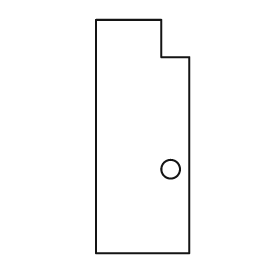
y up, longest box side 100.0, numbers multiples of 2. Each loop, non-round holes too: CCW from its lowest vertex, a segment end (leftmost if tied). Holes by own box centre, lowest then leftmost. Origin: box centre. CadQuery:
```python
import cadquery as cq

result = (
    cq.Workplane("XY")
    .moveTo(-20.0, -50.0)
    .lineTo(20.0, -50.0)
    .lineTo(20.0, 34.0)
    .lineTo(8.0, 34.0)
    .lineTo(8.0, 50.0)
    .lineTo(-20.0, 50.0)
    .close()
    .moveTo(12.0, -14.0)
    .circle(4.0)
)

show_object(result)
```